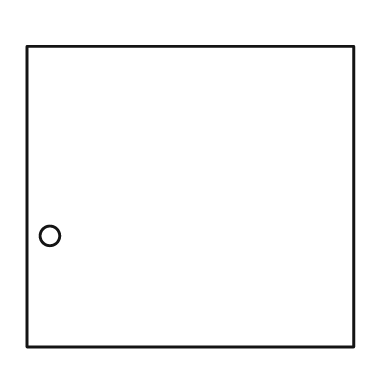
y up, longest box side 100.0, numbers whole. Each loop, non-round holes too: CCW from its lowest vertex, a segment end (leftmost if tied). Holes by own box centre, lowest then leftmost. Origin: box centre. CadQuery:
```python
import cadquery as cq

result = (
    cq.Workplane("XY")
    .moveTo(-50.0, -46.0)
    .lineTo(50.0, -46.0)
    .lineTo(50.0, 46.0)
    .lineTo(-50.0, 46.0)
    .close()
    .moveTo(-43.0, -12.0)
    .circle(3.0)
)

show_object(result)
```